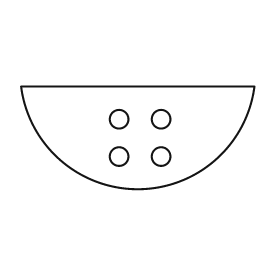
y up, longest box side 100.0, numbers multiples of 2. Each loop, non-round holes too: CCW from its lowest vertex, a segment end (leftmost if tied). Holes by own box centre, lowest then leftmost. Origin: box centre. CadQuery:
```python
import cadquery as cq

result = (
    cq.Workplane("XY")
    .moveTo(-50.0, 22.0)
    .threePointArc((0.0, -22.0), (50.0, 22.0))
    .close()
    .moveTo(-8.0, -8.0)
    .circle(4.0)
    .moveTo(10.0, -8.0)
    .circle(4.0)
    .moveTo(-8.0, 8.0)
    .circle(4.0)
    .moveTo(10.0, 8.0)
    .circle(4.0)
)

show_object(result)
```